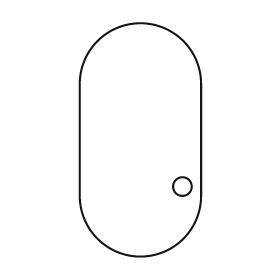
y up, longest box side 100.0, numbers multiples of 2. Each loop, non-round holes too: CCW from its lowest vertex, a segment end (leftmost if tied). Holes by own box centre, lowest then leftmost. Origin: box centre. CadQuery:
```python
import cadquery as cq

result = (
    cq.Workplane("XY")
    .moveTo(-26.0, -24.0)
    .threePointArc((0.0, -50.0), (26.0, -24.0))
    .lineTo(26.0, 24.0)
    .threePointArc((0.0, 50.0), (-26.0, 24.0))
    .close()
    .moveTo(18.0, -20.0)
    .circle(4.0)
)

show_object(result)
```